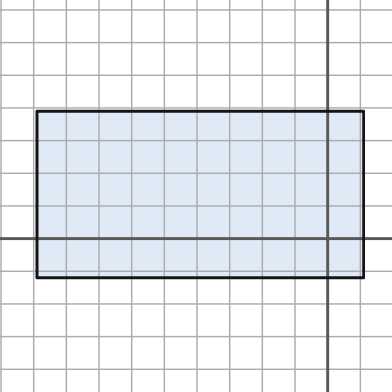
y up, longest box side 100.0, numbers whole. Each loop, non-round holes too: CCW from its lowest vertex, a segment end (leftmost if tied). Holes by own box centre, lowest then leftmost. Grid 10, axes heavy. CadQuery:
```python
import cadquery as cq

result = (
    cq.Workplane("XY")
    .moveTo(-89.0, -12.0)
    .lineTo(11.0, -12.0)
    .lineTo(11.0, 39.0)
    .lineTo(-89.0, 39.0)
    .close()
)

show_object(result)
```